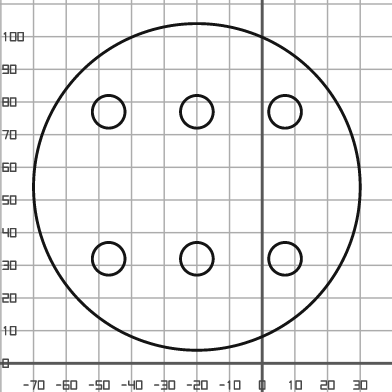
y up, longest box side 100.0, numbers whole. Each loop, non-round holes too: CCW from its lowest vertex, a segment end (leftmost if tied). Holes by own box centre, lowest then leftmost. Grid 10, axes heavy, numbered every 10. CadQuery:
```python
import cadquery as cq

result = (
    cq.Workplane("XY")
    .moveTo(-20.0, 54.0)
    .circle(50.0)
    .moveTo(-47.0, 32.0)
    .circle(5.0)
    .moveTo(-20.0, 32.0)
    .circle(5.0)
    .moveTo(7.0, 32.0)
    .circle(5.0)
    .moveTo(-47.0, 77.0)
    .circle(5.0)
    .moveTo(-20.0, 77.0)
    .circle(5.0)
    .moveTo(7.0, 77.0)
    .circle(5.0)
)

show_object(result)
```